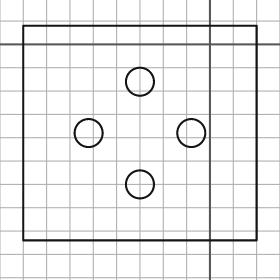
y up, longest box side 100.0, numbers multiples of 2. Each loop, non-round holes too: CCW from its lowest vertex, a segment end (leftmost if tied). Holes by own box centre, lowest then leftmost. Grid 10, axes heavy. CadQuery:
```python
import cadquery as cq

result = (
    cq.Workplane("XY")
    .moveTo(-80.0, -84.0)
    .lineTo(20.0, -84.0)
    .lineTo(20.0, 8.0)
    .lineTo(-80.0, 8.0)
    .close()
    .moveTo(-30.0, -60.0)
    .circle(6.0)
    .moveTo(-52.0, -38.0)
    .circle(6.0)
    .moveTo(-8.0, -38.0)
    .circle(6.0)
    .moveTo(-30.0, -16.0)
    .circle(6.0)
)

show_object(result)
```